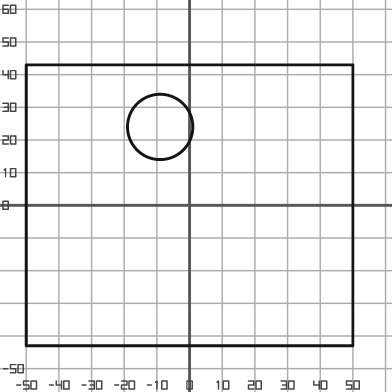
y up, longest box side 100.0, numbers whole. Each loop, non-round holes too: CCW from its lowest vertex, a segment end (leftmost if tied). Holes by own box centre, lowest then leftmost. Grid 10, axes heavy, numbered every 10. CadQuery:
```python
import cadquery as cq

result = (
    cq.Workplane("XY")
    .moveTo(-50.0, -43.0)
    .lineTo(50.0, -43.0)
    .lineTo(50.0, 43.0)
    .lineTo(-50.0, 43.0)
    .close()
    .moveTo(-9.0, 24.0)
    .circle(10.0)
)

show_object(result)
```